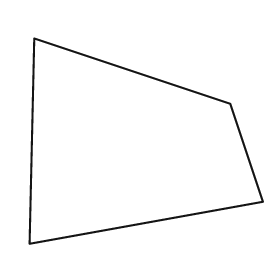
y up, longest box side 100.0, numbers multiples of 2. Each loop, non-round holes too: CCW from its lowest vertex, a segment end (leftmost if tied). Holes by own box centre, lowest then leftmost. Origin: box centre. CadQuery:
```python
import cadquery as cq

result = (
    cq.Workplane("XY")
    .moveTo(-50.0, -44.0)
    .lineTo(50.0, -26.0)
    .lineTo(36.0, 16.0)
    .lineTo(-48.0, 44.0)
    .close()
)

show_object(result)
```